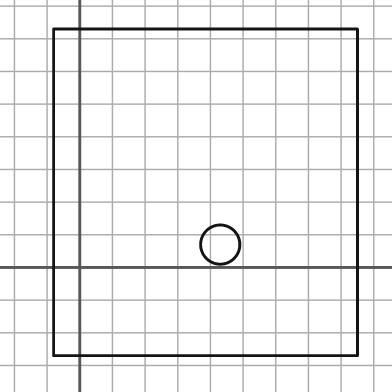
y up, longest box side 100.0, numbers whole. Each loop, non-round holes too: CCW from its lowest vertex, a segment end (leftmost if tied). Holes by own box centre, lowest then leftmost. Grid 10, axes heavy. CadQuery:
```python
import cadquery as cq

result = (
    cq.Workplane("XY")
    .moveTo(-8.0, -27.0)
    .lineTo(85.0, -27.0)
    .lineTo(85.0, 73.0)
    .lineTo(-8.0, 73.0)
    .close()
    .moveTo(43.0, 7.0)
    .circle(6.0)
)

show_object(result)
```